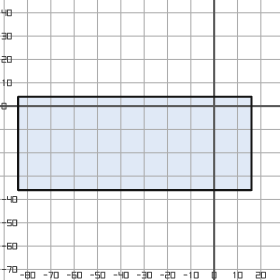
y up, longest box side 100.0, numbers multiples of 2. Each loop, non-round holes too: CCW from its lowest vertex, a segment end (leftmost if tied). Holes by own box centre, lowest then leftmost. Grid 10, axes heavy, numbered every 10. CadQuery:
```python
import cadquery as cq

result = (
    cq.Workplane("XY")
    .moveTo(-84.0, -36.0)
    .lineTo(16.0, -36.0)
    .lineTo(16.0, 4.0)
    .lineTo(-84.0, 4.0)
    .close()
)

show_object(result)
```